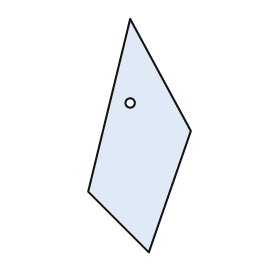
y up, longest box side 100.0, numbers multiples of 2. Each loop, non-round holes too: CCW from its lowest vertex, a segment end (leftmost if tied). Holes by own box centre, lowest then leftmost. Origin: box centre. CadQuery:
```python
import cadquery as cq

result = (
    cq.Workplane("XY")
    .moveTo(4.0, -50.0)
    .lineTo(22.0, 2.0)
    .lineTo(-4.0, 50.0)
    .lineTo(-22.0, -24.0)
    .close()
    .moveTo(-4.0, 14.0)
    .circle(2.0)
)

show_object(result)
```